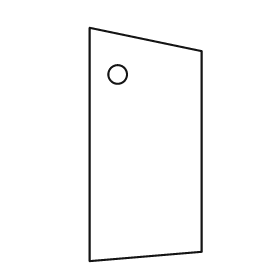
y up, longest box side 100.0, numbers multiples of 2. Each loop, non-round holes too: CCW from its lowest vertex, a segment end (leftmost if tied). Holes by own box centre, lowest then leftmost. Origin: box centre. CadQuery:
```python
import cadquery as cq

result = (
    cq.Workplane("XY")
    .moveTo(-24.0, -50.0)
    .lineTo(24.0, -46.0)
    .lineTo(24.0, 40.0)
    .lineTo(-24.0, 50.0)
    .close()
    .moveTo(-12.0, 30.0)
    .circle(4.0)
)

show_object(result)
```